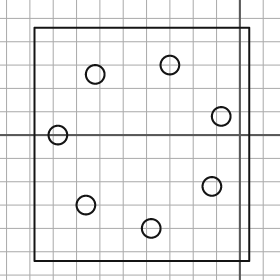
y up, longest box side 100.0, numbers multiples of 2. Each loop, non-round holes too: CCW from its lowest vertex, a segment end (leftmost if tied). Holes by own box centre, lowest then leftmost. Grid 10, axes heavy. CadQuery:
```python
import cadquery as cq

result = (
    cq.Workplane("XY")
    .moveTo(-88.0, -54.0)
    .lineTo(4.0, -54.0)
    .lineTo(4.0, 46.0)
    .lineTo(-88.0, 46.0)
    .close()
    .moveTo(-38.0, -40.0)
    .circle(4.0)
    .moveTo(-66.0, -30.0)
    .circle(4.0)
    .moveTo(-12.0, -22.0)
    .circle(4.0)
    .moveTo(-78.0, 0.0)
    .circle(4.0)
    .moveTo(-8.0, 8.0)
    .circle(4.0)
    .moveTo(-62.0, 26.0)
    .circle(4.0)
    .moveTo(-30.0, 30.0)
    .circle(4.0)
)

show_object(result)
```